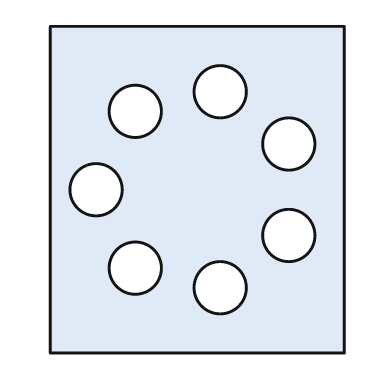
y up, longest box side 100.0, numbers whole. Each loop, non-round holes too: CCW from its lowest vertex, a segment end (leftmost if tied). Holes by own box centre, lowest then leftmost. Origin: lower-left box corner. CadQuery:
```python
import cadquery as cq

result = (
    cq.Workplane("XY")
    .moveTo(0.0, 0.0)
    .lineTo(90.0, 0.0)
    .lineTo(90.0, 100.0)
    .lineTo(0.0, 100.0)
    .close()
    .moveTo(52.0, 20.0)
    .circle(8.0)
    .moveTo(26.0, 26.0)
    .circle(8.0)
    .moveTo(73.0, 36.0)
    .circle(8.0)
    .moveTo(14.0, 50.0)
    .circle(8.0)
    .moveTo(73.0, 64.0)
    .circle(8.0)
    .moveTo(26.0, 74.0)
    .circle(8.0)
    .moveTo(52.0, 80.0)
    .circle(8.0)
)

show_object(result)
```